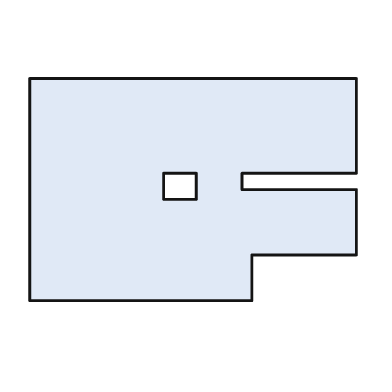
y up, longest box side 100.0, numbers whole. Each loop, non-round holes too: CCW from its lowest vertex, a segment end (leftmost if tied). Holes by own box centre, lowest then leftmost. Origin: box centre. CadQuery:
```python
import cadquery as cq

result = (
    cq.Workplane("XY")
    .moveTo(-50.0, -34.0)
    .lineTo(18.0, -34.0)
    .lineTo(18.0, -20.0)
    .lineTo(50.0, -20.0)
    .lineTo(50.0, 0.0)
    .lineTo(15.0, 0.0)
    .lineTo(15.0, 5.0)
    .lineTo(50.0, 5.0)
    .lineTo(50.0, 34.0)
    .lineTo(-50.0, 34.0)
    .close()
    .moveTo(-9.0, -3.0)
    .lineTo(1.0, -3.0)
    .lineTo(1.0, 5.0)
    .lineTo(-9.0, 5.0)
    .close()
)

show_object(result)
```